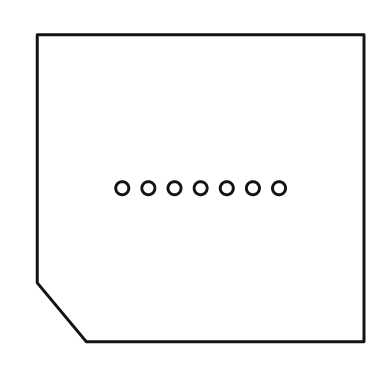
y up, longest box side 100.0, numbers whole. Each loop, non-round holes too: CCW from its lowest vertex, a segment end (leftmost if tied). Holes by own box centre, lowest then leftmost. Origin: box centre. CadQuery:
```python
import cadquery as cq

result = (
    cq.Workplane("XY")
    .moveTo(-35.0, -47.0)
    .lineTo(50.0, -47.0)
    .lineTo(50.0, 47.0)
    .lineTo(-50.0, 47.0)
    .lineTo(-50.0, -29.0)
    .close()
    .moveTo(-24.0, 0.0)
    .circle(2.0)
    .moveTo(-16.0, 0.0)
    .circle(2.0)
    .moveTo(-8.0, 0.0)
    .circle(2.0)
    .moveTo(0.0, 0.0)
    .circle(2.0)
    .moveTo(8.0, 0.0)
    .circle(2.0)
    .moveTo(16.0, 0.0)
    .circle(2.0)
    .moveTo(24.0, 0.0)
    .circle(2.0)
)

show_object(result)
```